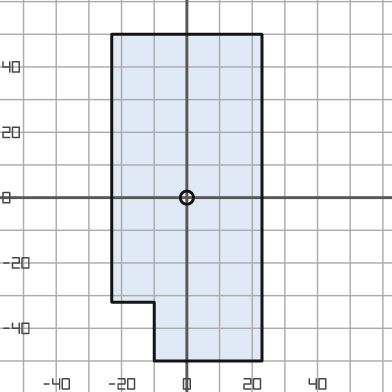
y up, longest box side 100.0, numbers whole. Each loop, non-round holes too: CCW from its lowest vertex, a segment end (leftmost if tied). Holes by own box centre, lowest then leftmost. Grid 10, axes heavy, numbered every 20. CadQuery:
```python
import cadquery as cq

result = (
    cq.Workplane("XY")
    .moveTo(-10.0, -50.0)
    .lineTo(23.0, -50.0)
    .lineTo(23.0, 50.0)
    .lineTo(-23.0, 50.0)
    .lineTo(-23.0, -32.0)
    .lineTo(-10.0, -32.0)
    .close()
    .moveTo(0.0, 0.0)
    .circle(2.0)
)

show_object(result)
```